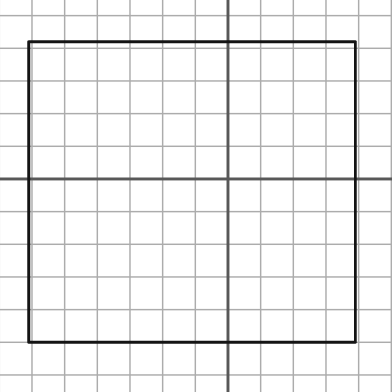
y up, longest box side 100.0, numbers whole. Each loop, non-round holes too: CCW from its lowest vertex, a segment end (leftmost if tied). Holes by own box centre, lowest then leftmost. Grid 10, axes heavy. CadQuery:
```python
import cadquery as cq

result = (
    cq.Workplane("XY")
    .moveTo(-61.0, -50.0)
    .lineTo(39.0, -50.0)
    .lineTo(39.0, 42.0)
    .lineTo(-61.0, 42.0)
    .close()
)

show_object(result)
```